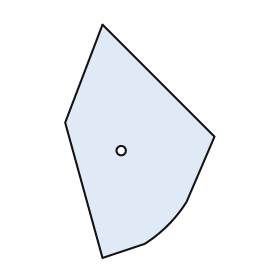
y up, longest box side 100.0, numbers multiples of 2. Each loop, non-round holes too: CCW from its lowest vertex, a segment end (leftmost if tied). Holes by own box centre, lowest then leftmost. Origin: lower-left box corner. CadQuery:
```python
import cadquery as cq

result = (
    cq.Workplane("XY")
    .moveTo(16.0, 0.0)
    .lineTo(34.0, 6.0)
    .threePointArc((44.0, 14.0), (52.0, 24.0))
    .lineTo(64.0, 52.0)
    .lineTo(16.0, 100.0)
    .lineTo(0.0, 58.0)
    .close()
    .moveTo(24.0, 46.0)
    .circle(2.0)
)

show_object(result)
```